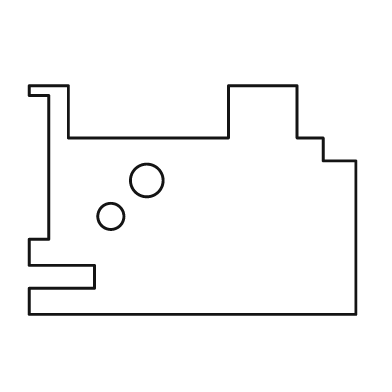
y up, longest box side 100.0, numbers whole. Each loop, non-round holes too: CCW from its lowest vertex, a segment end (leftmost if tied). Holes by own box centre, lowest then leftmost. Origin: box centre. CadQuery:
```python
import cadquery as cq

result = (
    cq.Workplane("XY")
    .moveTo(-50.0, -35.0)
    .lineTo(50.0, -35.0)
    .lineTo(50.0, 12.0)
    .lineTo(40.0, 12.0)
    .lineTo(40.0, 19.0)
    .lineTo(32.0, 19.0)
    .lineTo(32.0, 35.0)
    .lineTo(11.0, 35.0)
    .lineTo(11.0, 19.0)
    .lineTo(-38.0, 19.0)
    .lineTo(-38.0, 35.0)
    .lineTo(-50.0, 35.0)
    .lineTo(-50.0, 32.0)
    .lineTo(-44.0, 32.0)
    .lineTo(-44.0, -12.0)
    .lineTo(-50.0, -12.0)
    .lineTo(-50.0, -20.0)
    .lineTo(-30.0, -20.0)
    .lineTo(-30.0, -27.0)
    .lineTo(-50.0, -27.0)
    .close()
    .moveTo(-25.0, -5.0)
    .circle(4.0)
    .moveTo(-14.0, 6.0)
    .circle(5.0)
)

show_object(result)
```